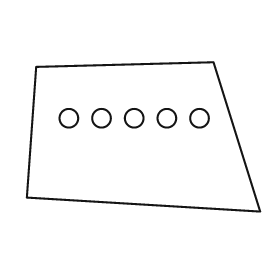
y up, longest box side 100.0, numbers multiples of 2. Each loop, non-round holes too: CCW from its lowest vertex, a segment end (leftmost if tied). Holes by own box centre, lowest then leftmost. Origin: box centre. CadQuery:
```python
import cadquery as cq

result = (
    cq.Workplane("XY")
    .moveTo(50.0, -32.0)
    .lineTo(30.0, 32.0)
    .lineTo(-46.0, 30.0)
    .lineTo(-50.0, -26.0)
    .close()
    .moveTo(-32.0, 8.0)
    .circle(4.0)
    .moveTo(-18.0, 8.0)
    .circle(4.0)
    .moveTo(-4.0, 8.0)
    .circle(4.0)
    .moveTo(10.0, 8.0)
    .circle(4.0)
    .moveTo(24.0, 8.0)
    .circle(4.0)
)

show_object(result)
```